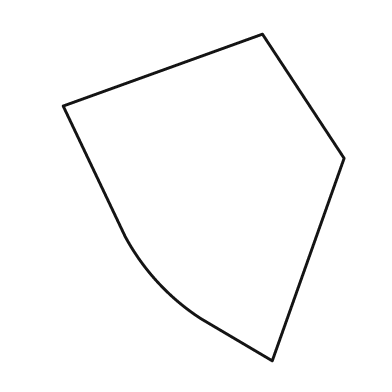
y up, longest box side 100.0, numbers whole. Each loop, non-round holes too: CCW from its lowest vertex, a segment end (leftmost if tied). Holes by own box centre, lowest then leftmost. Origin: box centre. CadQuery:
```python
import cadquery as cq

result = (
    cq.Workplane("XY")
    .moveTo(21.0, -50.0)
    .lineTo(43.0, 12.0)
    .lineTo(18.0, 50.0)
    .lineTo(-43.0, 28.0)
    .lineTo(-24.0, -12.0)
    .threePointArc((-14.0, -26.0), (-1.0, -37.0))
    .close()
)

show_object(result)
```